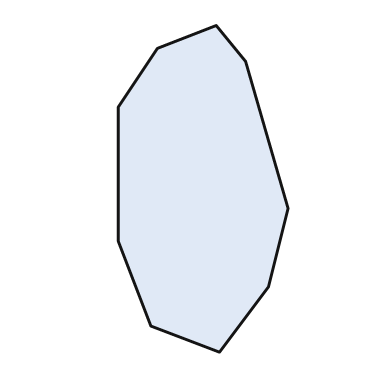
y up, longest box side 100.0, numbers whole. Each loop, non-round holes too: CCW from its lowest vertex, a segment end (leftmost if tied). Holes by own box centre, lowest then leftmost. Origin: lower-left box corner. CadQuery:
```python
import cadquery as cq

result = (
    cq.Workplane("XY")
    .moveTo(31.0, 0.0)
    .lineTo(46.0, 20.0)
    .lineTo(52.0, 44.0)
    .lineTo(39.0, 89.0)
    .lineTo(30.0, 100.0)
    .lineTo(12.0, 93.0)
    .lineTo(0.0, 75.0)
    .lineTo(0.0, 34.0)
    .lineTo(10.0, 8.0)
    .close()
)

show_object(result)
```